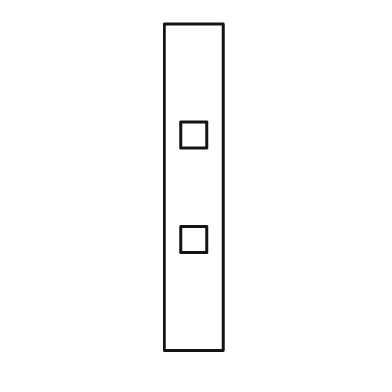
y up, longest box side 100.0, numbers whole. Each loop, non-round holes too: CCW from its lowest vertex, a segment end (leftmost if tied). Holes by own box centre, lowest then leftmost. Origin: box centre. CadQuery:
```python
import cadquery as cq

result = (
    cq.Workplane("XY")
    .moveTo(-9.0, -50.0)
    .lineTo(9.0, -50.0)
    .lineTo(9.0, 50.0)
    .lineTo(-9.0, 50.0)
    .close()
    .moveTo(-4.0, -20.0)
    .lineTo(4.0, -20.0)
    .lineTo(4.0, -12.0)
    .lineTo(-4.0, -12.0)
    .close()
    .moveTo(-4.0, 12.0)
    .lineTo(4.0, 12.0)
    .lineTo(4.0, 20.0)
    .lineTo(-4.0, 20.0)
    .close()
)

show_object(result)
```